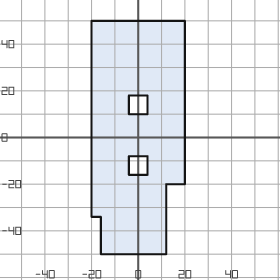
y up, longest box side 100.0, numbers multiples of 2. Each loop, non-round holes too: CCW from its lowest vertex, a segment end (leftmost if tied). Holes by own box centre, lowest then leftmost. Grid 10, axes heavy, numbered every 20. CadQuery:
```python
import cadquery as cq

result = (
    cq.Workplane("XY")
    .moveTo(-16.0, -50.0)
    .lineTo(12.0, -50.0)
    .lineTo(12.0, -20.0)
    .lineTo(20.0, -20.0)
    .lineTo(20.0, 50.0)
    .lineTo(-20.0, 50.0)
    .lineTo(-20.0, -34.0)
    .lineTo(-16.0, -34.0)
    .close()
    .moveTo(-4.0, -16.0)
    .lineTo(4.0, -16.0)
    .lineTo(4.0, -8.0)
    .lineTo(-4.0, -8.0)
    .close()
    .moveTo(-4.0, 10.0)
    .lineTo(4.0, 10.0)
    .lineTo(4.0, 18.0)
    .lineTo(-4.0, 18.0)
    .close()
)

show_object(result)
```